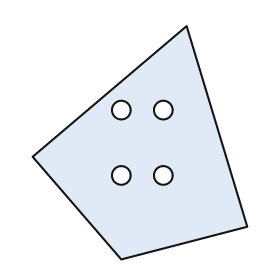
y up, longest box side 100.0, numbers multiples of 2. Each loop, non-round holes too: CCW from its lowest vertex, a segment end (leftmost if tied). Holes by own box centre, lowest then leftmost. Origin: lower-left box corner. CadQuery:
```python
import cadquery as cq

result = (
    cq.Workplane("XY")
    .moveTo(38.0, 0.0)
    .lineTo(92.0, 14.0)
    .lineTo(66.0, 100.0)
    .lineTo(0.0, 44.0)
    .close()
    .moveTo(38.0, 36.0)
    .circle(4.0)
    .moveTo(56.0, 36.0)
    .circle(4.0)
    .moveTo(38.0, 64.0)
    .circle(4.0)
    .moveTo(56.0, 64.0)
    .circle(4.0)
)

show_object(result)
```